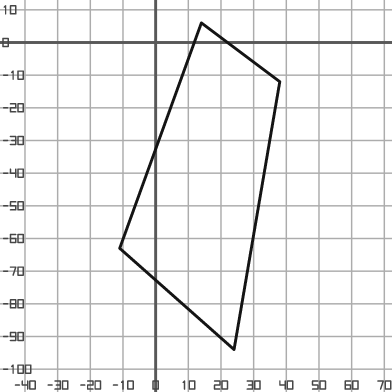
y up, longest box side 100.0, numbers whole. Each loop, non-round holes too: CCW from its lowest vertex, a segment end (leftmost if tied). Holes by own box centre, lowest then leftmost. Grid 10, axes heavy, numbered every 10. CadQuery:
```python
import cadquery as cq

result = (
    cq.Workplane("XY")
    .moveTo(24.0, -94.0)
    .lineTo(38.0, -12.0)
    .lineTo(14.0, 6.0)
    .lineTo(-11.0, -63.0)
    .close()
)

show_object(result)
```